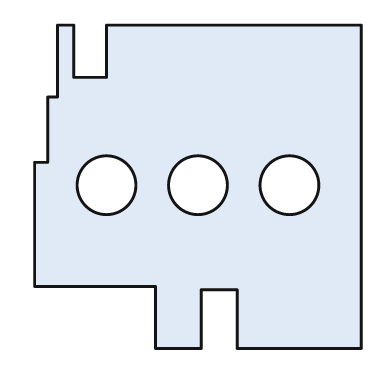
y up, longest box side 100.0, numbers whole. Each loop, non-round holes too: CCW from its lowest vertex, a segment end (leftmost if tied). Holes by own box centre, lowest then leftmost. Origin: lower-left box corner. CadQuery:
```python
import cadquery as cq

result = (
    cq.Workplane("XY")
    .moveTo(37.0, 0.0)
    .lineTo(51.0, 0.0)
    .lineTo(51.0, 18.0)
    .lineTo(62.0, 18.0)
    .lineTo(62.0, 0.0)
    .lineTo(100.0, 0.0)
    .lineTo(100.0, 99.0)
    .lineTo(22.0, 99.0)
    .lineTo(22.0, 83.0)
    .lineTo(12.0, 83.0)
    .lineTo(12.0, 99.0)
    .lineTo(7.0, 99.0)
    .lineTo(7.0, 77.0)
    .lineTo(4.0, 77.0)
    .lineTo(4.0, 57.0)
    .lineTo(0.0, 57.0)
    .lineTo(0.0, 19.0)
    .lineTo(37.0, 19.0)
    .close()
    .moveTo(22.0, 50.0)
    .circle(9.0)
    .moveTo(50.0, 50.0)
    .circle(9.0)
    .moveTo(78.0, 50.0)
    .circle(9.0)
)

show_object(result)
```